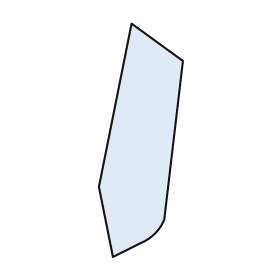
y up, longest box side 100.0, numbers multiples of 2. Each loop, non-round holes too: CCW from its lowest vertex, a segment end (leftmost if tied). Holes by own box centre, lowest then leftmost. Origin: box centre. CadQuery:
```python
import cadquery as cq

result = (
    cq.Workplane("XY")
    .moveTo(-12.0, -50.0)
    .lineTo(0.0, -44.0)
    .threePointArc((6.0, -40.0), (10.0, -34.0))
    .lineTo(18.0, 34.0)
    .lineTo(-4.0, 50.0)
    .lineTo(-18.0, -20.0)
    .close()
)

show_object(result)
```